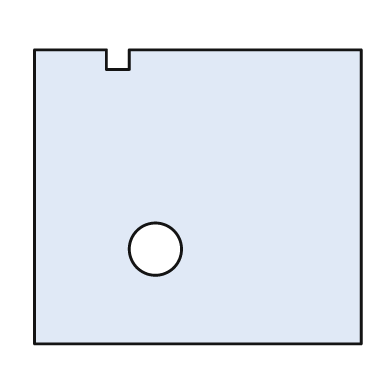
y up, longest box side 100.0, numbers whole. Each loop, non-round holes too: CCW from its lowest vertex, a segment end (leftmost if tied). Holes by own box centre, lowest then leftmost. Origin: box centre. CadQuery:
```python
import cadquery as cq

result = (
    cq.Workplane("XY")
    .moveTo(-50.0, -45.0)
    .lineTo(50.0, -45.0)
    .lineTo(50.0, 45.0)
    .lineTo(-21.0, 45.0)
    .lineTo(-21.0, 39.0)
    .lineTo(-28.0, 39.0)
    .lineTo(-28.0, 45.0)
    .lineTo(-50.0, 45.0)
    .close()
    .moveTo(-13.0, -16.0)
    .circle(8.0)
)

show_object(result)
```